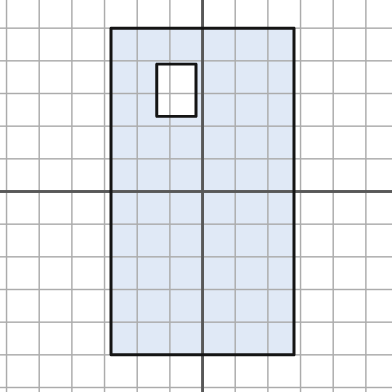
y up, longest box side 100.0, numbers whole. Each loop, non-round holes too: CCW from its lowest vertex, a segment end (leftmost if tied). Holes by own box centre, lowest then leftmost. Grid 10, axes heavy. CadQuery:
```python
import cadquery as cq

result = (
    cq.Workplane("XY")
    .moveTo(-28.0, -50.0)
    .lineTo(28.0, -50.0)
    .lineTo(28.0, 50.0)
    .lineTo(-28.0, 50.0)
    .close()
    .moveTo(-14.0, 23.0)
    .lineTo(-2.0, 23.0)
    .lineTo(-2.0, 39.0)
    .lineTo(-14.0, 39.0)
    .close()
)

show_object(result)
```